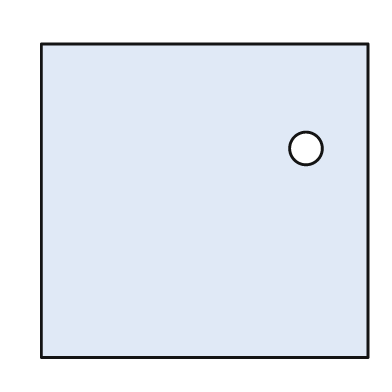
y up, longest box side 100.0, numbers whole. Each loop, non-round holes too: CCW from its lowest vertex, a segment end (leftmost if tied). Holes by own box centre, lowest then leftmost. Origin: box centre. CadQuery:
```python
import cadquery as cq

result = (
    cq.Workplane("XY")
    .moveTo(-50.0, -48.0)
    .lineTo(50.0, -48.0)
    .lineTo(50.0, 48.0)
    .lineTo(-50.0, 48.0)
    .close()
    .moveTo(31.0, 16.0)
    .circle(5.0)
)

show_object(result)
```